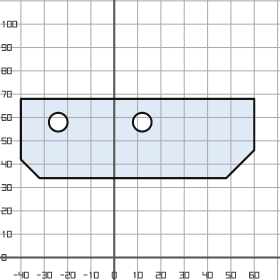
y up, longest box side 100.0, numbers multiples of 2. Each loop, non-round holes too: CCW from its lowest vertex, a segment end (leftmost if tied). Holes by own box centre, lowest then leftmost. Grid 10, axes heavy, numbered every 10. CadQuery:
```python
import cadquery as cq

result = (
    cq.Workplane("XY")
    .moveTo(-32.0, 34.0)
    .lineTo(48.0, 34.0)
    .lineTo(60.0, 46.0)
    .lineTo(60.0, 68.0)
    .lineTo(-40.0, 68.0)
    .lineTo(-40.0, 42.0)
    .close()
    .moveTo(-24.0, 58.0)
    .circle(4.0)
    .moveTo(12.0, 58.0)
    .circle(4.0)
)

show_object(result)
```